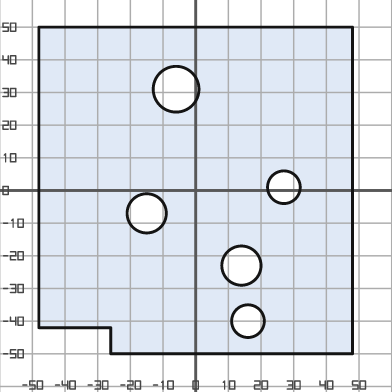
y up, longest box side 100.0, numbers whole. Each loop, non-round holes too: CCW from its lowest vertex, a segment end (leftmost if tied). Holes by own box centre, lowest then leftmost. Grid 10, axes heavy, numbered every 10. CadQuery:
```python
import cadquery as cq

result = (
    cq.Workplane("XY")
    .moveTo(-26.0, -50.0)
    .lineTo(48.0, -50.0)
    .lineTo(48.0, 50.0)
    .lineTo(-48.0, 50.0)
    .lineTo(-48.0, -42.0)
    .lineTo(-26.0, -42.0)
    .close()
    .moveTo(16.0, -40.0)
    .circle(5.0)
    .moveTo(14.0, -23.0)
    .circle(6.0)
    .moveTo(-15.0, -7.0)
    .circle(6.0)
    .moveTo(27.0, 1.0)
    .circle(5.0)
    .moveTo(-6.0, 31.0)
    .circle(7.0)
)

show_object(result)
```